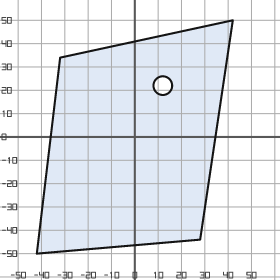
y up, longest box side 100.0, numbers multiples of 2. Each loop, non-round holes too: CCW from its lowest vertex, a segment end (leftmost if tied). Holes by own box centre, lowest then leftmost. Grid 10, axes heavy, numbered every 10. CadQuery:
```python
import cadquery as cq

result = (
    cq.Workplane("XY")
    .moveTo(-42.0, -50.0)
    .lineTo(28.0, -44.0)
    .lineTo(42.0, 50.0)
    .lineTo(-32.0, 34.0)
    .close()
    .moveTo(12.0, 22.0)
    .circle(4.0)
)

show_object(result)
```